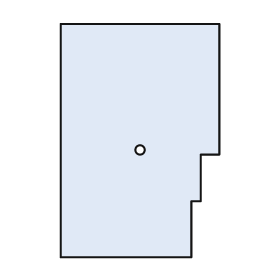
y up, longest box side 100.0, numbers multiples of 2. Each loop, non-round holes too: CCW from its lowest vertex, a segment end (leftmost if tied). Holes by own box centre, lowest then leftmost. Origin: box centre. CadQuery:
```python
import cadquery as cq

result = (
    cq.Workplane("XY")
    .moveTo(-34.0, -50.0)
    .lineTo(22.0, -50.0)
    .lineTo(22.0, -26.0)
    .lineTo(26.0, -26.0)
    .lineTo(26.0, -6.0)
    .lineTo(34.0, -6.0)
    .lineTo(34.0, 50.0)
    .lineTo(-34.0, 50.0)
    .close()
    .moveTo(0.0, -4.0)
    .circle(2.0)
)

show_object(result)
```